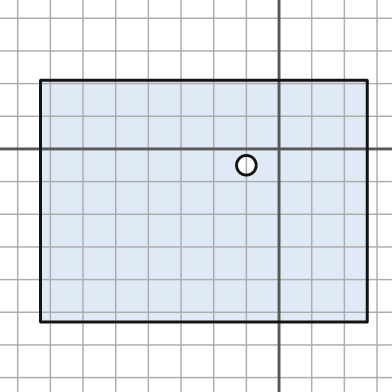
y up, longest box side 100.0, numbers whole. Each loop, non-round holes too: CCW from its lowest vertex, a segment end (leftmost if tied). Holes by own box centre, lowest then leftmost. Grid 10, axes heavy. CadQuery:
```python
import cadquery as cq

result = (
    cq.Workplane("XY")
    .moveTo(-73.0, -53.0)
    .lineTo(27.0, -53.0)
    .lineTo(27.0, 21.0)
    .lineTo(-73.0, 21.0)
    .close()
    .moveTo(-10.0, -5.0)
    .circle(3.0)
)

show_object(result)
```